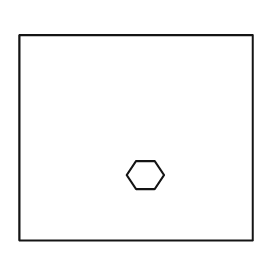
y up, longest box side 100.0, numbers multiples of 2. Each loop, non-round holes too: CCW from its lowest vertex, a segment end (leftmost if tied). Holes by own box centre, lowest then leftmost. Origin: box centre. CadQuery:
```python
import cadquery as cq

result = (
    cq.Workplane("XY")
    .moveTo(-50.0, -44.0)
    .lineTo(50.0, -44.0)
    .lineTo(50.0, 44.0)
    .lineTo(-50.0, 44.0)
    .close()
    .moveTo(0.0, -22.0)
    .lineTo(8.0, -22.0)
    .lineTo(12.0, -16.0)
    .lineTo(8.0, -10.0)
    .lineTo(0.0, -10.0)
    .lineTo(-4.0, -16.0)
    .close()
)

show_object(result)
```